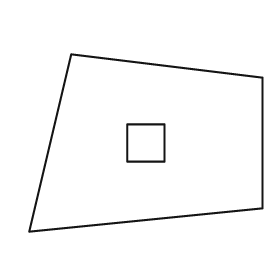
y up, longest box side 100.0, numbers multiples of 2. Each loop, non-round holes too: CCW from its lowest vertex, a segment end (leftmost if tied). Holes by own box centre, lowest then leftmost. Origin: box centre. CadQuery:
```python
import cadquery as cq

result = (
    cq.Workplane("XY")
    .moveTo(-50.0, -38.0)
    .lineTo(50.0, -28.0)
    .lineTo(50.0, 28.0)
    .lineTo(-32.0, 38.0)
    .close()
    .moveTo(-8.0, -8.0)
    .lineTo(8.0, -8.0)
    .lineTo(8.0, 8.0)
    .lineTo(-8.0, 8.0)
    .close()
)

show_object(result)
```